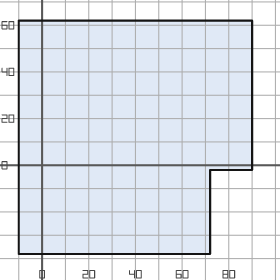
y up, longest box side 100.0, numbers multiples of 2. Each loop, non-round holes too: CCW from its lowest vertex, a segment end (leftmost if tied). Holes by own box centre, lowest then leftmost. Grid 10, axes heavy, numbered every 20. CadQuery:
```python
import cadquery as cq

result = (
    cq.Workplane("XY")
    .moveTo(-10.0, -38.0)
    .lineTo(72.0, -38.0)
    .lineTo(72.0, -2.0)
    .lineTo(90.0, -2.0)
    .lineTo(90.0, 62.0)
    .lineTo(-10.0, 62.0)
    .close()
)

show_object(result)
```